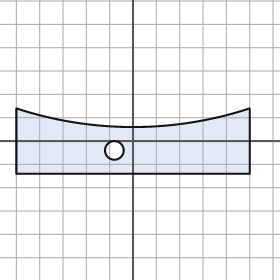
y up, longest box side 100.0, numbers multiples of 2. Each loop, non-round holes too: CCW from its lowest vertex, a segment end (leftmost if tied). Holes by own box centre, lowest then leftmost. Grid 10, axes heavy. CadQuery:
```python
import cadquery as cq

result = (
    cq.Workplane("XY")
    .moveTo(-50.0, -14.0)
    .lineTo(50.0, -14.0)
    .lineTo(50.0, 14.0)
    .threePointArc((0.0, 6.0), (-50.0, 14.0))
    .close()
    .moveTo(-8.0, -4.0)
    .circle(4.0)
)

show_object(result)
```